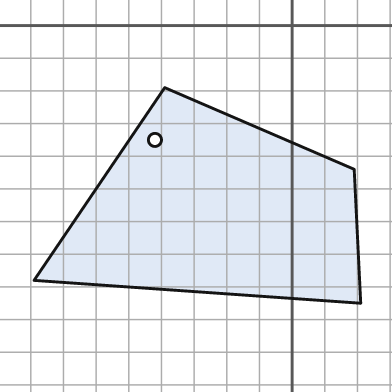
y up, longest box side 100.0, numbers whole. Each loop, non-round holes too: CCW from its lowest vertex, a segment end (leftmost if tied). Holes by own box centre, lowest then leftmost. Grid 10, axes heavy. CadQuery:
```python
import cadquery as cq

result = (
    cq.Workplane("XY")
    .moveTo(21.0, -85.0)
    .lineTo(19.0, -44.0)
    .lineTo(-39.0, -19.0)
    .lineTo(-79.0, -78.0)
    .close()
    .moveTo(-42.0, -35.0)
    .circle(2.0)
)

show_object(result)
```